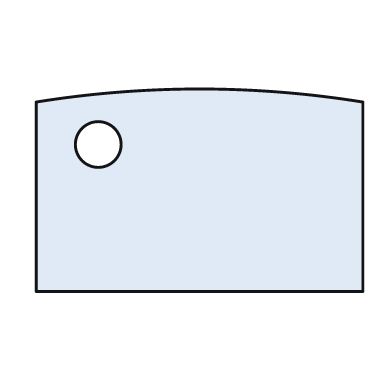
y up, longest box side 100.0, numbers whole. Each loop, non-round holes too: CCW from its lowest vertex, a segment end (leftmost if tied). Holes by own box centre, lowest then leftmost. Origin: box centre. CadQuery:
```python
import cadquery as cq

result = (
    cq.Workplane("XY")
    .moveTo(-50.0, -31.0)
    .lineTo(50.0, -31.0)
    .lineTo(50.0, 27.0)
    .threePointArc((0.0, 31.0), (-50.0, 27.0))
    .close()
    .moveTo(-31.0, 14.0)
    .circle(7.0)
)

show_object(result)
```